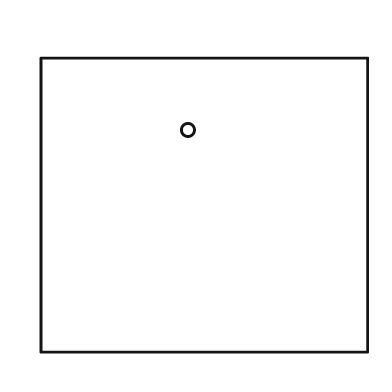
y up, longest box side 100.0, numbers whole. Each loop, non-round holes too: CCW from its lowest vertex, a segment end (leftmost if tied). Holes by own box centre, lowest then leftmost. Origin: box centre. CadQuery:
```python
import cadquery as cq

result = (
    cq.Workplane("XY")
    .moveTo(-50.0, -45.0)
    .lineTo(50.0, -45.0)
    .lineTo(50.0, 45.0)
    .lineTo(-50.0, 45.0)
    .close()
    .moveTo(-5.0, 23.0)
    .circle(2.0)
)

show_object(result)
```